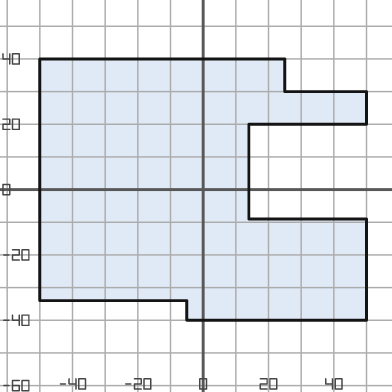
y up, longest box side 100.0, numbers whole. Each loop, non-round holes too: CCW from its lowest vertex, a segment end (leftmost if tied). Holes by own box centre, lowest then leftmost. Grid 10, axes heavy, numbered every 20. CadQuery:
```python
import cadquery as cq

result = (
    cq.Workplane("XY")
    .moveTo(-5.0, -40.0)
    .lineTo(50.0, -40.0)
    .lineTo(50.0, -9.0)
    .lineTo(14.0, -9.0)
    .lineTo(14.0, 20.0)
    .lineTo(50.0, 20.0)
    .lineTo(50.0, 30.0)
    .lineTo(25.0, 30.0)
    .lineTo(25.0, 40.0)
    .lineTo(-50.0, 40.0)
    .lineTo(-50.0, -34.0)
    .lineTo(-5.0, -34.0)
    .close()
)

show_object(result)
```